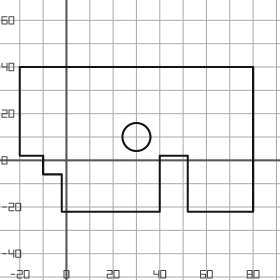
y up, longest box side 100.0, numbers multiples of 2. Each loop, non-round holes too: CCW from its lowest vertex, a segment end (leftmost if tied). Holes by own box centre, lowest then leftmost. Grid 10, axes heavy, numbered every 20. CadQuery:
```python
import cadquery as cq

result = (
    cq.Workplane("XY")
    .moveTo(-2.0, -22.0)
    .lineTo(40.0, -22.0)
    .lineTo(40.0, 2.0)
    .lineTo(52.0, 2.0)
    .lineTo(52.0, -22.0)
    .lineTo(80.0, -22.0)
    .lineTo(80.0, 40.0)
    .lineTo(-20.0, 40.0)
    .lineTo(-20.0, 2.0)
    .lineTo(-10.0, 2.0)
    .lineTo(-10.0, -6.0)
    .lineTo(-2.0, -6.0)
    .close()
    .moveTo(30.0, 10.0)
    .circle(6.0)
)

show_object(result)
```